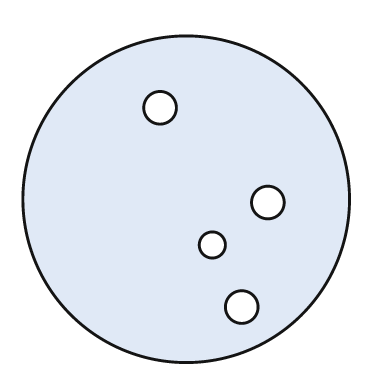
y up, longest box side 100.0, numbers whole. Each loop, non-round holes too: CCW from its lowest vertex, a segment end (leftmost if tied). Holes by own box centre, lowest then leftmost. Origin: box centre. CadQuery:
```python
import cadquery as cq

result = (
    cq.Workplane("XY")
    .moveTo(0.0, 0.0)
    .circle(50.0)
    .moveTo(17.0, -33.0)
    .circle(5.0)
    .moveTo(8.0, -14.0)
    .circle(4.0)
    .moveTo(25.0, -1.0)
    .circle(5.0)
    .moveTo(-8.0, 28.0)
    .circle(5.0)
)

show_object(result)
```